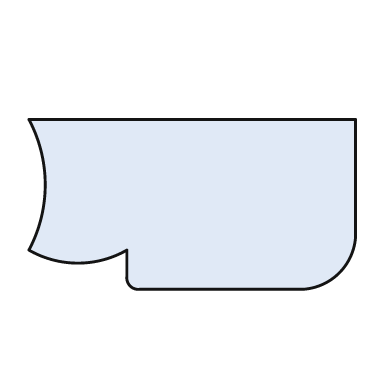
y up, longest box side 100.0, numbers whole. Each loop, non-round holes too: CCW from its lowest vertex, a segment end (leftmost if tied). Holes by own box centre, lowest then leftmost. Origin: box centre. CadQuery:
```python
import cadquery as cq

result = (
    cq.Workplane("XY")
    .moveTo(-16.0, -26.0)
    .lineTo(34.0, -26.0)
    .threePointArc((45.0, -21.0), (50.0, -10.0))
    .lineTo(50.0, 26.0)
    .lineTo(-50.0, 26.0)
    .threePointArc((-45.0, 6.0), (-50.0, -14.0))
    .threePointArc((-35.0, -18.0), (-20.0, -14.0))
    .lineTo(-20.0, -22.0)
    .threePointArc((-19.0, -25.0), (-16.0, -26.0))
    .close()
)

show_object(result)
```